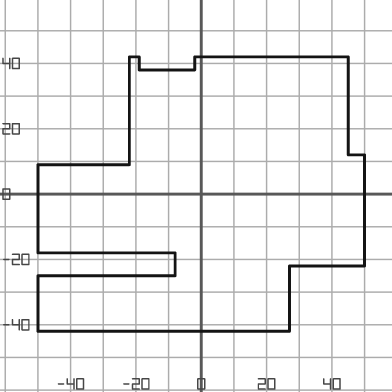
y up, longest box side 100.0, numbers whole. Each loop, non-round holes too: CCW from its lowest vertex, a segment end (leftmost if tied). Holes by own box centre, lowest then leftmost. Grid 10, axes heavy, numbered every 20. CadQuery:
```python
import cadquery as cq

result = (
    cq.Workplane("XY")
    .moveTo(-50.0, -42.0)
    .lineTo(27.0, -42.0)
    .lineTo(27.0, -22.0)
    .lineTo(50.0, -22.0)
    .lineTo(50.0, 12.0)
    .lineTo(45.0, 12.0)
    .lineTo(45.0, 42.0)
    .lineTo(-2.0, 42.0)
    .lineTo(-2.0, 38.0)
    .lineTo(-19.0, 38.0)
    .lineTo(-19.0, 42.0)
    .lineTo(-22.0, 42.0)
    .lineTo(-22.0, 9.0)
    .lineTo(-50.0, 9.0)
    .lineTo(-50.0, -18.0)
    .lineTo(-8.0, -18.0)
    .lineTo(-8.0, -25.0)
    .lineTo(-50.0, -25.0)
    .close()
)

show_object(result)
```